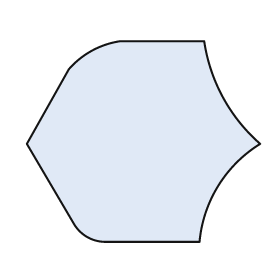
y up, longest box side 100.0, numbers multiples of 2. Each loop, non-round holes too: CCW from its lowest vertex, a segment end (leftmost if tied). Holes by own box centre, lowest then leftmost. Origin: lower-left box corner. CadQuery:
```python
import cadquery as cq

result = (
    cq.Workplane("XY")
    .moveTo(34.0, 0.0)
    .lineTo(74.0, 0.0)
    .threePointArc((82.0, 24.0), (100.0, 42.0))
    .threePointArc((84.0, 62.0), (76.0, 86.0))
    .lineTo(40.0, 86.0)
    .threePointArc((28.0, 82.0), (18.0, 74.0))
    .lineTo(0.0, 42.0)
    .lineTo(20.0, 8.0)
    .threePointArc((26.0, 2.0), (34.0, 0.0))
    .close()
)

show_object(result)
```